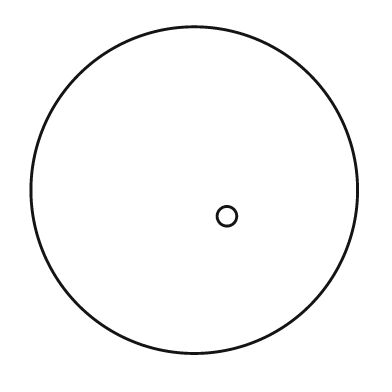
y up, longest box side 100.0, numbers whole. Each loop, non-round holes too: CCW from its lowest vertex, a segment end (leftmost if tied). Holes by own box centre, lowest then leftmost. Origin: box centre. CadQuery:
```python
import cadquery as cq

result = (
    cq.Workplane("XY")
    .moveTo(0.0, 0.0)
    .circle(50.0)
    .moveTo(10.0, -8.0)
    .circle(3.0)
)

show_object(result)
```